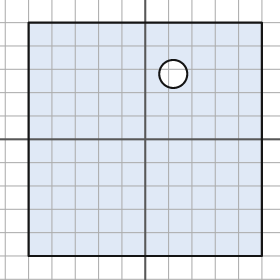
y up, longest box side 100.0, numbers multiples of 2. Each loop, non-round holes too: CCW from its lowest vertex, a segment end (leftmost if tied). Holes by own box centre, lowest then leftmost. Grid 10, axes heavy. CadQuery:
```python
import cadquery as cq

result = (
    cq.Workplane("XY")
    .moveTo(-50.0, -50.0)
    .lineTo(50.0, -50.0)
    .lineTo(50.0, 50.0)
    .lineTo(-50.0, 50.0)
    .close()
    .moveTo(12.0, 28.0)
    .circle(6.0)
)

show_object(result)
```